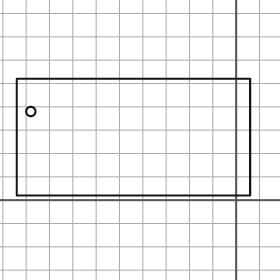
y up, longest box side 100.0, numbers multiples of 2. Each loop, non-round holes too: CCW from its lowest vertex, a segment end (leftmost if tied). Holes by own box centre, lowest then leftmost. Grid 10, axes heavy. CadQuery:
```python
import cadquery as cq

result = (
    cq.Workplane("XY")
    .moveTo(-94.0, 2.0)
    .lineTo(6.0, 2.0)
    .lineTo(6.0, 52.0)
    .lineTo(-94.0, 52.0)
    .close()
    .moveTo(-88.0, 38.0)
    .circle(2.0)
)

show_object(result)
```